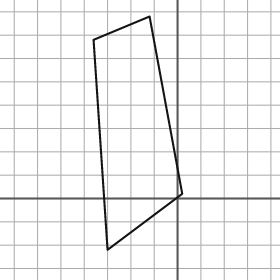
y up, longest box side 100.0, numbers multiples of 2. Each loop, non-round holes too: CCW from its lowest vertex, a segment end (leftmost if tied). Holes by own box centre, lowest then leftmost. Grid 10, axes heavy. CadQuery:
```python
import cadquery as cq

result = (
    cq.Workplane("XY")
    .moveTo(-30.0, -22.0)
    .lineTo(2.0, 2.0)
    .lineTo(-12.0, 78.0)
    .lineTo(-36.0, 68.0)
    .close()
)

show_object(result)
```